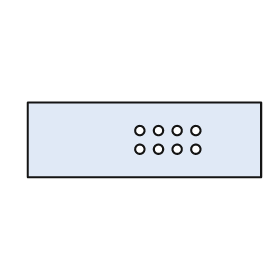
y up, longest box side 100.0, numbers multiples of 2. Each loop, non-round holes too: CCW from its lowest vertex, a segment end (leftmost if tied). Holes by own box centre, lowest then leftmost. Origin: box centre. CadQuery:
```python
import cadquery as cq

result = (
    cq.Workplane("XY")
    .moveTo(-50.0, -16.0)
    .lineTo(50.0, -16.0)
    .lineTo(50.0, 16.0)
    .lineTo(-50.0, 16.0)
    .close()
    .moveTo(-2.0, -4.0)
    .circle(2.0)
    .moveTo(6.0, -4.0)
    .circle(2.0)
    .moveTo(14.0, -4.0)
    .circle(2.0)
    .moveTo(22.0, -4.0)
    .circle(2.0)
    .moveTo(-2.0, 4.0)
    .circle(2.0)
    .moveTo(6.0, 4.0)
    .circle(2.0)
    .moveTo(14.0, 4.0)
    .circle(2.0)
    .moveTo(22.0, 4.0)
    .circle(2.0)
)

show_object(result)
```